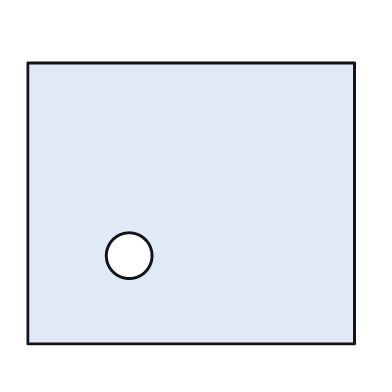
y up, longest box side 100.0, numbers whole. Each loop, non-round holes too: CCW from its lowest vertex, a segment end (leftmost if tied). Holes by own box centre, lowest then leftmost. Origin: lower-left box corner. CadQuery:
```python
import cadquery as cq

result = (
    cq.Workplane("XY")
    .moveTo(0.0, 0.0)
    .lineTo(100.0, 0.0)
    .lineTo(100.0, 86.0)
    .lineTo(0.0, 86.0)
    .close()
    .moveTo(31.0, 27.0)
    .circle(7.0)
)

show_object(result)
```